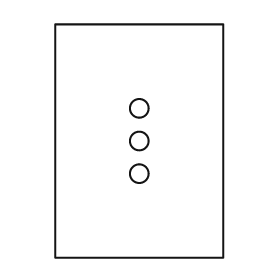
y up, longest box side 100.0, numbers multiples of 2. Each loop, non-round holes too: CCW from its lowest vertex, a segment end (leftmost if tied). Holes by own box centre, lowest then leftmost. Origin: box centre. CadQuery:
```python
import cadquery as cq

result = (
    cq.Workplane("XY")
    .moveTo(-36.0, -50.0)
    .lineTo(36.0, -50.0)
    .lineTo(36.0, 50.0)
    .lineTo(-36.0, 50.0)
    .close()
    .moveTo(0.0, -14.0)
    .circle(4.0)
    .moveTo(0.0, 0.0)
    .circle(4.0)
    .moveTo(0.0, 14.0)
    .circle(4.0)
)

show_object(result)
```